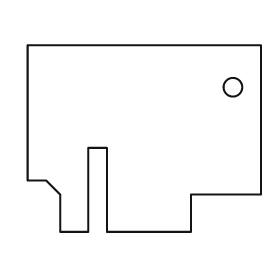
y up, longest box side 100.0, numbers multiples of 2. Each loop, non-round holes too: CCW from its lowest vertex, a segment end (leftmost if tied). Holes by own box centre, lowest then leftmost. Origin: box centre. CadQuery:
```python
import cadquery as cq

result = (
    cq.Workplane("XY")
    .moveTo(-36.0, -40.0)
    .lineTo(-24.0, -40.0)
    .lineTo(-24.0, -4.0)
    .lineTo(-16.0, -4.0)
    .lineTo(-16.0, -40.0)
    .lineTo(20.0, -40.0)
    .lineTo(20.0, -24.0)
    .lineTo(50.0, -24.0)
    .lineTo(50.0, 40.0)
    .lineTo(-50.0, 40.0)
    .lineTo(-50.0, -18.0)
    .lineTo(-42.0, -18.0)
    .lineTo(-36.0, -24.0)
    .close()
    .moveTo(38.0, 22.0)
    .circle(4.0)
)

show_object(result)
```